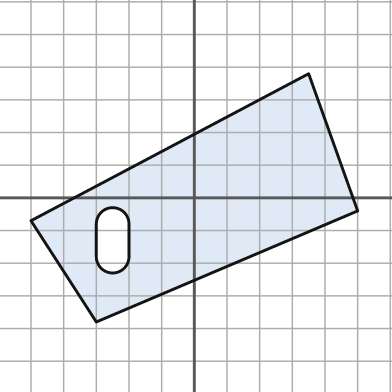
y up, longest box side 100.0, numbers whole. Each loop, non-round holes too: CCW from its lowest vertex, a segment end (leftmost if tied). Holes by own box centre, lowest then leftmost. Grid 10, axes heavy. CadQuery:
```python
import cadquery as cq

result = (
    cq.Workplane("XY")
    .moveTo(-30.0, -38.0)
    .lineTo(50.0, -4.0)
    .lineTo(35.0, 38.0)
    .lineTo(-50.0, -7.0)
    .close()
    .moveTo(-30.0, -18.0)
    .threePointArc((-25.0, -23.0), (-20.0, -18.0))
    .lineTo(-20.0, -8.0)
    .threePointArc((-25.0, -3.0), (-30.0, -8.0))
    .close()
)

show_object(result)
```